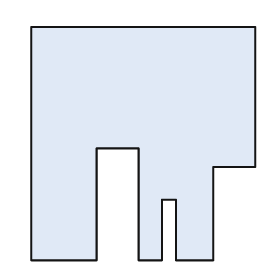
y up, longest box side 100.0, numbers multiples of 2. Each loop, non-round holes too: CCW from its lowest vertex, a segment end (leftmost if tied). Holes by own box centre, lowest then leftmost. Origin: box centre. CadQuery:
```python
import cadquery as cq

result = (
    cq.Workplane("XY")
    .moveTo(-48.0, -50.0)
    .lineTo(-20.0, -50.0)
    .lineTo(-20.0, -2.0)
    .lineTo(-2.0, -2.0)
    .lineTo(-2.0, -50.0)
    .lineTo(8.0, -50.0)
    .lineTo(8.0, -24.0)
    .lineTo(14.0, -24.0)
    .lineTo(14.0, -50.0)
    .lineTo(30.0, -50.0)
    .lineTo(30.0, -10.0)
    .lineTo(48.0, -10.0)
    .lineTo(48.0, 50.0)
    .lineTo(-48.0, 50.0)
    .close()
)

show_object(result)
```